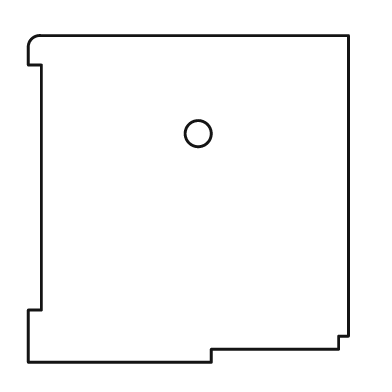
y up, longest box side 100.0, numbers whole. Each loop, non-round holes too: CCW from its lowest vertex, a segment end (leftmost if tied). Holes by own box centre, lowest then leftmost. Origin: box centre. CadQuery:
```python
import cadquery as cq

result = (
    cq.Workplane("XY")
    .moveTo(-49.0, -50.0)
    .lineTo(7.0, -50.0)
    .lineTo(7.0, -46.0)
    .lineTo(46.0, -46.0)
    .lineTo(46.0, -42.0)
    .lineTo(49.0, -42.0)
    .lineTo(49.0, 50.0)
    .lineTo(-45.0, 50.0)
    .threePointArc((-48.0, 49.0), (-49.0, 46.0))
    .lineTo(-49.0, 41.0)
    .lineTo(-45.0, 41.0)
    .lineTo(-45.0, -34.0)
    .lineTo(-49.0, -34.0)
    .close()
    .moveTo(3.0, 20.0)
    .circle(4.0)
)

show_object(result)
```